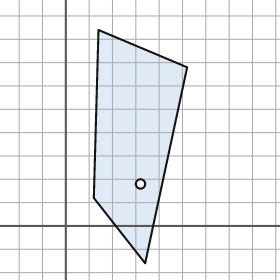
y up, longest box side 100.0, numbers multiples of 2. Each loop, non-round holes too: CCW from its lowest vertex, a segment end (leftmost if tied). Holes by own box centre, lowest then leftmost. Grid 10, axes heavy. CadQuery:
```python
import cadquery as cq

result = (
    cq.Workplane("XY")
    .moveTo(34.0, -16.0)
    .lineTo(52.0, 68.0)
    .lineTo(14.0, 84.0)
    .lineTo(12.0, 12.0)
    .close()
    .moveTo(32.0, 18.0)
    .circle(2.0)
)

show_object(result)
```